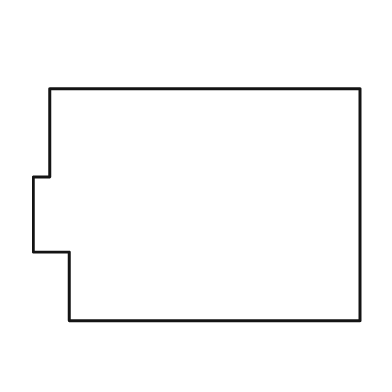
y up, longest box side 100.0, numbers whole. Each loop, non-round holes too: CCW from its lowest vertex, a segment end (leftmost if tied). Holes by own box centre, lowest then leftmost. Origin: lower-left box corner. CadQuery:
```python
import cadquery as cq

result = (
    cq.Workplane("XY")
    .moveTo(11.0, 0.0)
    .lineTo(100.0, 0.0)
    .lineTo(100.0, 71.0)
    .lineTo(5.0, 71.0)
    .lineTo(5.0, 44.0)
    .lineTo(0.0, 44.0)
    .lineTo(0.0, 21.0)
    .lineTo(11.0, 21.0)
    .close()
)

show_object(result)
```